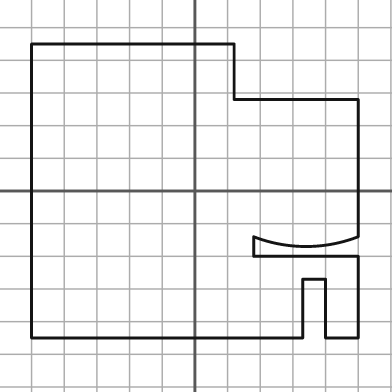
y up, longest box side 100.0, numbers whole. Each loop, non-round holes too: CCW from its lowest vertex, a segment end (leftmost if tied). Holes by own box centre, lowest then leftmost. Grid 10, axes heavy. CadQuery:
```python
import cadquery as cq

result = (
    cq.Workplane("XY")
    .moveTo(-50.0, -45.0)
    .lineTo(33.0, -45.0)
    .lineTo(33.0, -27.0)
    .lineTo(40.0, -27.0)
    .lineTo(40.0, -45.0)
    .lineTo(50.0, -45.0)
    .lineTo(50.0, -20.0)
    .lineTo(18.0, -20.0)
    .lineTo(18.0, -14.0)
    .threePointArc((34.0, -17.0), (50.0, -14.0))
    .lineTo(50.0, 28.0)
    .lineTo(12.0, 28.0)
    .lineTo(12.0, 45.0)
    .lineTo(-50.0, 45.0)
    .close()
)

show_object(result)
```